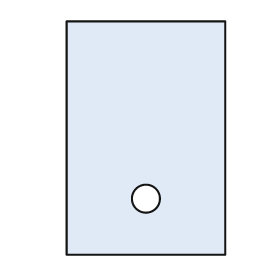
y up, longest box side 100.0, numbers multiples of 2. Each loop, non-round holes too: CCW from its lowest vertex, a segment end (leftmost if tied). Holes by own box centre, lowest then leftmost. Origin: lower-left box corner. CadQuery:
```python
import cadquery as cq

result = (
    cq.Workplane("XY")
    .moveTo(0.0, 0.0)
    .lineTo(68.0, 0.0)
    .lineTo(68.0, 100.0)
    .lineTo(0.0, 100.0)
    .close()
    .moveTo(34.0, 24.0)
    .circle(6.0)
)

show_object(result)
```